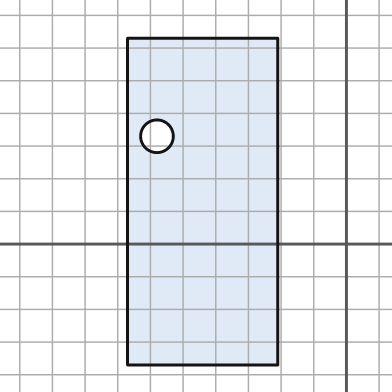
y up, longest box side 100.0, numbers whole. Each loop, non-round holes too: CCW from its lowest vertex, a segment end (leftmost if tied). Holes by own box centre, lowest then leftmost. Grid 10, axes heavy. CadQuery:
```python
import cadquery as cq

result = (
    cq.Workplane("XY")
    .moveTo(-67.0, -37.0)
    .lineTo(-21.0, -37.0)
    .lineTo(-21.0, 63.0)
    .lineTo(-67.0, 63.0)
    .close()
    .moveTo(-58.0, 33.0)
    .circle(5.0)
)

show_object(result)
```